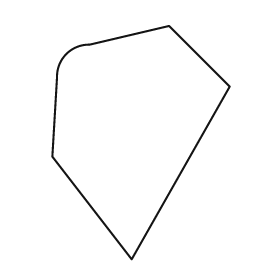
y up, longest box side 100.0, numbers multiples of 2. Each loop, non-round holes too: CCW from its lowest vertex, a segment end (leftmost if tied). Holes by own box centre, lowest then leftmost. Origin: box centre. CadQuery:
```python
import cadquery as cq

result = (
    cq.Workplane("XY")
    .moveTo(-4.0, -50.0)
    .lineTo(38.0, 24.0)
    .lineTo(12.0, 50.0)
    .lineTo(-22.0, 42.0)
    .threePointArc((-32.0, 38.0), (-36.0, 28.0))
    .lineTo(-38.0, -6.0)
    .close()
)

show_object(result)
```